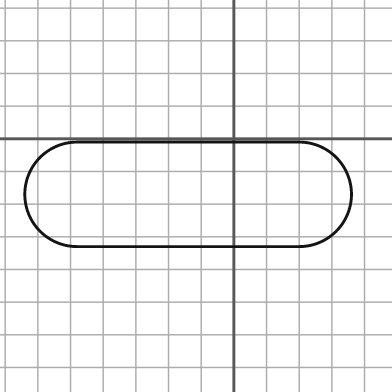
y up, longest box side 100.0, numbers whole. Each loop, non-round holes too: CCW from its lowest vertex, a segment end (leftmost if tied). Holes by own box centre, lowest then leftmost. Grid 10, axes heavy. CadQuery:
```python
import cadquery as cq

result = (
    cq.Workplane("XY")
    .moveTo(-48.0, -33.0)
    .lineTo(20.0, -33.0)
    .threePointArc((36.0, -17.0), (20.0, -1.0))
    .lineTo(-48.0, -1.0)
    .threePointArc((-64.0, -17.0), (-48.0, -33.0))
    .close()
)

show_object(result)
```